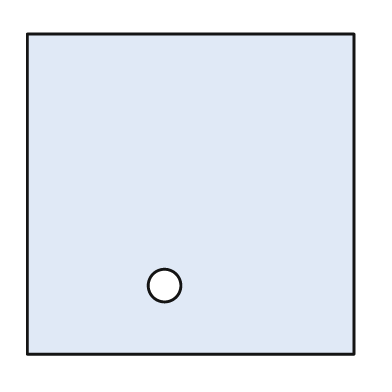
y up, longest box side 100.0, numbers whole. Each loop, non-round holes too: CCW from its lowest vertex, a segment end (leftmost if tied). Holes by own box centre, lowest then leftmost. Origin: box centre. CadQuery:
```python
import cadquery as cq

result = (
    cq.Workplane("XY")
    .moveTo(-50.0, -49.0)
    .lineTo(50.0, -49.0)
    .lineTo(50.0, 49.0)
    .lineTo(-50.0, 49.0)
    .close()
    .moveTo(-8.0, -28.0)
    .circle(5.0)
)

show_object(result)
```